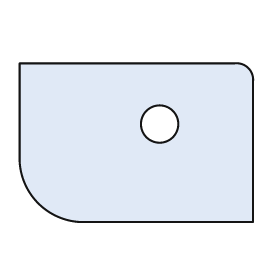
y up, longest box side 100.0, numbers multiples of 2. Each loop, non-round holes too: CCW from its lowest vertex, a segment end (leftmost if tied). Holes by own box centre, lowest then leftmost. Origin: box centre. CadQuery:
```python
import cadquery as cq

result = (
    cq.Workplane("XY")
    .moveTo(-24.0, -34.0)
    .lineTo(50.0, -34.0)
    .lineTo(50.0, 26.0)
    .threePointArc((48.0, 32.0), (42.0, 34.0))
    .lineTo(-50.0, 34.0)
    .lineTo(-50.0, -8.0)
    .threePointArc((-42.0, -26.0), (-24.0, -34.0))
    .close()
    .moveTo(10.0, 8.0)
    .circle(8.0)
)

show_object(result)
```